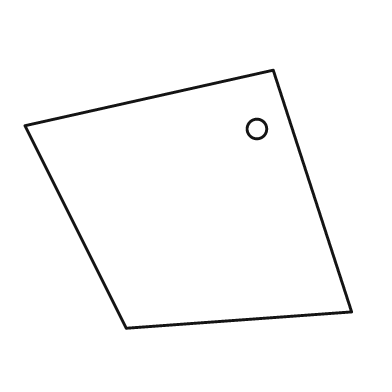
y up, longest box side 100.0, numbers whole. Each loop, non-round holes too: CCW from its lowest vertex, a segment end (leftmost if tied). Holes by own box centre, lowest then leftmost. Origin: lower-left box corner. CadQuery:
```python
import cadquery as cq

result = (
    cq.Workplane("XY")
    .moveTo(31.0, 0.0)
    .lineTo(100.0, 5.0)
    .lineTo(76.0, 79.0)
    .lineTo(0.0, 62.0)
    .close()
    .moveTo(71.0, 61.0)
    .circle(3.0)
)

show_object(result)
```